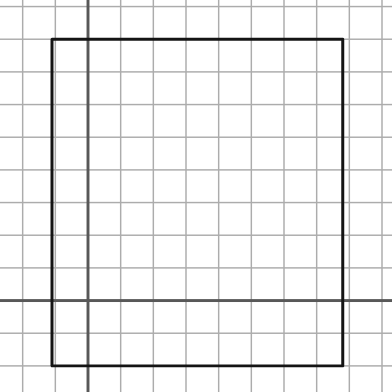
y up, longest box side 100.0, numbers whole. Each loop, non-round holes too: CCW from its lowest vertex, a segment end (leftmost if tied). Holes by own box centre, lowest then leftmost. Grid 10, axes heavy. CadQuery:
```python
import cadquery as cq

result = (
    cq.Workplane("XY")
    .moveTo(-11.0, -20.0)
    .lineTo(78.0, -20.0)
    .lineTo(78.0, 80.0)
    .lineTo(-11.0, 80.0)
    .close()
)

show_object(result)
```